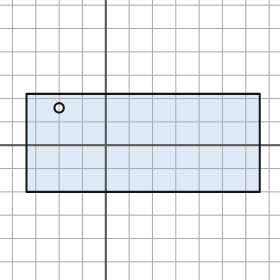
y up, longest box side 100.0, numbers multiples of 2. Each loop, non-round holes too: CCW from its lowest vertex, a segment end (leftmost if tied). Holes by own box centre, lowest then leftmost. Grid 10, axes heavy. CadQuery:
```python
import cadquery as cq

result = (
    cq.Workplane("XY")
    .moveTo(-34.0, -20.0)
    .lineTo(66.0, -20.0)
    .lineTo(66.0, 22.0)
    .lineTo(-34.0, 22.0)
    .close()
    .moveTo(-20.0, 16.0)
    .circle(2.0)
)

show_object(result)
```